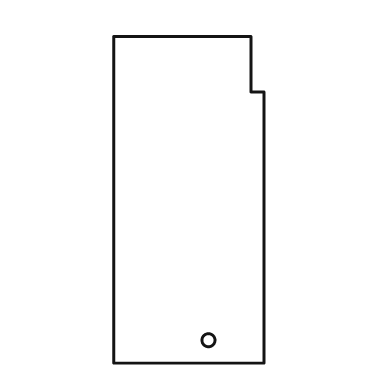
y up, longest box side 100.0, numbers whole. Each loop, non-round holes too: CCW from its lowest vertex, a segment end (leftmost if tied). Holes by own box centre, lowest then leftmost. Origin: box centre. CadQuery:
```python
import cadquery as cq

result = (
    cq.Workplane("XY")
    .moveTo(-23.0, -50.0)
    .lineTo(23.0, -50.0)
    .lineTo(23.0, 33.0)
    .lineTo(19.0, 33.0)
    .lineTo(19.0, 50.0)
    .lineTo(-23.0, 50.0)
    .close()
    .moveTo(6.0, -43.0)
    .circle(2.0)
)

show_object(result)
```